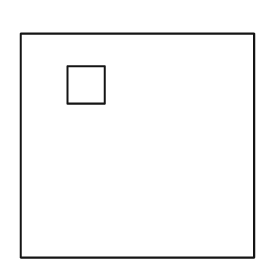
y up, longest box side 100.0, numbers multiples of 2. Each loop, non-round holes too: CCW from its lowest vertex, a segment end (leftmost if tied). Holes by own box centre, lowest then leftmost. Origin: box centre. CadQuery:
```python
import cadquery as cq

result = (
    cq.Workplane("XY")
    .moveTo(-50.0, -48.0)
    .lineTo(50.0, -48.0)
    .lineTo(50.0, 48.0)
    .lineTo(-50.0, 48.0)
    .close()
    .moveTo(-30.0, 18.0)
    .lineTo(-14.0, 18.0)
    .lineTo(-14.0, 34.0)
    .lineTo(-30.0, 34.0)
    .close()
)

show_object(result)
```